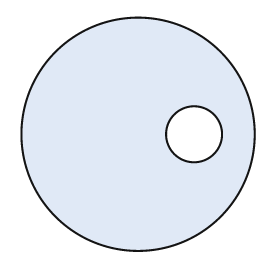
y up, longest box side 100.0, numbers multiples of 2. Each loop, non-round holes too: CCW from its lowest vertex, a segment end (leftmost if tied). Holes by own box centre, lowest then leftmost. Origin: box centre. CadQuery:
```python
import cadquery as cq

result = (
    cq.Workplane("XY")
    .moveTo(0.0, 0.0)
    .circle(50.0)
    .moveTo(24.0, 0.0)
    .circle(12.0)
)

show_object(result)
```